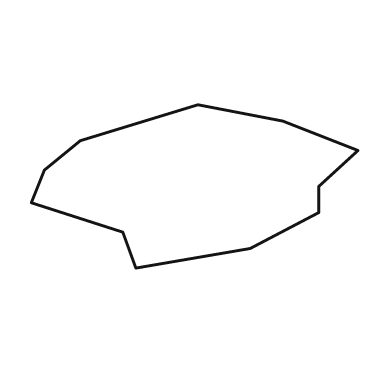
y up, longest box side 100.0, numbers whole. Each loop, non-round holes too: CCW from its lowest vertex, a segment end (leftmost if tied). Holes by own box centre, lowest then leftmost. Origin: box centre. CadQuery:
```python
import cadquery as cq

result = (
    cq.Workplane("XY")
    .moveTo(-18.0, -25.0)
    .lineTo(17.0, -19.0)
    .lineTo(38.0, -8.0)
    .lineTo(38.0, 0.0)
    .lineTo(50.0, 11.0)
    .lineTo(27.0, 20.0)
    .lineTo(1.0, 25.0)
    .lineTo(-35.0, 14.0)
    .lineTo(-46.0, 5.0)
    .lineTo(-50.0, -5.0)
    .lineTo(-22.0, -14.0)
    .close()
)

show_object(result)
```